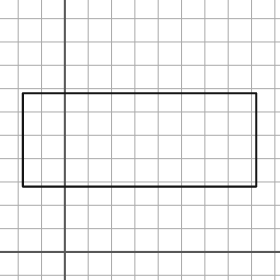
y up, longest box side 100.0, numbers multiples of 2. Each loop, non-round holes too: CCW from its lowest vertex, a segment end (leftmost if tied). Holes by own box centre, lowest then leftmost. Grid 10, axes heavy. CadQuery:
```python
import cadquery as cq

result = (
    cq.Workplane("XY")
    .moveTo(-18.0, 28.0)
    .lineTo(82.0, 28.0)
    .lineTo(82.0, 68.0)
    .lineTo(-18.0, 68.0)
    .close()
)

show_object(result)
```